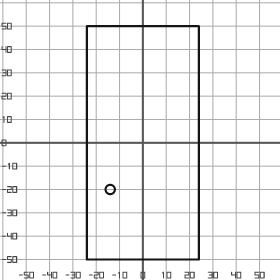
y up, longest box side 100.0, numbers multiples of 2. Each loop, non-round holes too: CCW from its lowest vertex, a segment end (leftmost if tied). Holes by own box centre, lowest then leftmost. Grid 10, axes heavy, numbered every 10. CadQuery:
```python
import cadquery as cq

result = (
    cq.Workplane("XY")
    .moveTo(-24.0, -50.0)
    .lineTo(24.0, -50.0)
    .lineTo(24.0, 50.0)
    .lineTo(-24.0, 50.0)
    .close()
    .moveTo(-14.0, -20.0)
    .circle(2.0)
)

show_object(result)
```